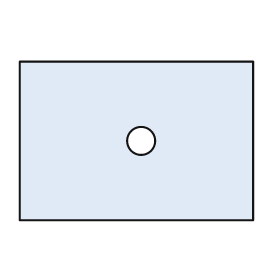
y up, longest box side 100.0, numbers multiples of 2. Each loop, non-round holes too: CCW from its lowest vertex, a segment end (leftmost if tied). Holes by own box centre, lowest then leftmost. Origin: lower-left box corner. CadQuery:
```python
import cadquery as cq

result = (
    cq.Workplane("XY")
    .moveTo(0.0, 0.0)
    .lineTo(100.0, 0.0)
    .lineTo(100.0, 68.0)
    .lineTo(0.0, 68.0)
    .close()
    .moveTo(52.0, 34.0)
    .circle(6.0)
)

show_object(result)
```